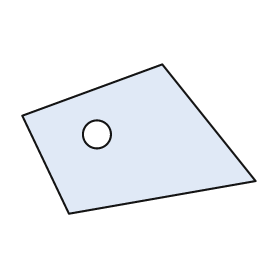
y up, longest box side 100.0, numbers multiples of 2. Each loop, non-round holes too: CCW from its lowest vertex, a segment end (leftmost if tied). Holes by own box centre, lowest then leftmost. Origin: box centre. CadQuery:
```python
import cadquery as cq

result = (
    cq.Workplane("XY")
    .moveTo(-30.0, -32.0)
    .lineTo(50.0, -18.0)
    .lineTo(10.0, 32.0)
    .lineTo(-50.0, 10.0)
    .close()
    .moveTo(-18.0, 2.0)
    .circle(6.0)
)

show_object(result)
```